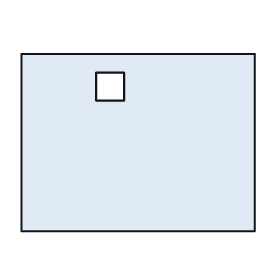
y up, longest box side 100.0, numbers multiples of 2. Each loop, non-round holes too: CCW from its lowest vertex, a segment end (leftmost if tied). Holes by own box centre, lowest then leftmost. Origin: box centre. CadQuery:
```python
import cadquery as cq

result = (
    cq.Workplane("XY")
    .moveTo(-50.0, -38.0)
    .lineTo(50.0, -38.0)
    .lineTo(50.0, 38.0)
    .lineTo(-50.0, 38.0)
    .close()
    .moveTo(-18.0, 18.0)
    .lineTo(-6.0, 18.0)
    .lineTo(-6.0, 30.0)
    .lineTo(-18.0, 30.0)
    .close()
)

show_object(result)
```